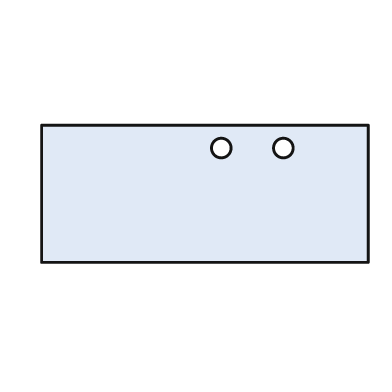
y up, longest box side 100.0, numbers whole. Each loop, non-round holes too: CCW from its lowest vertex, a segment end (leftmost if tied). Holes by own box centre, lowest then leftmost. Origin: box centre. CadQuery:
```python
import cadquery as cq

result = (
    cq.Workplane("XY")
    .moveTo(-50.0, -21.0)
    .lineTo(50.0, -21.0)
    .lineTo(50.0, 21.0)
    .lineTo(-50.0, 21.0)
    .close()
    .moveTo(5.0, 14.0)
    .circle(3.0)
    .moveTo(24.0, 14.0)
    .circle(3.0)
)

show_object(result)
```